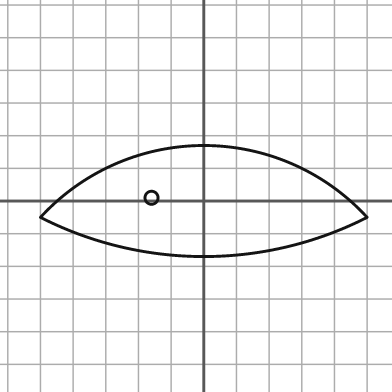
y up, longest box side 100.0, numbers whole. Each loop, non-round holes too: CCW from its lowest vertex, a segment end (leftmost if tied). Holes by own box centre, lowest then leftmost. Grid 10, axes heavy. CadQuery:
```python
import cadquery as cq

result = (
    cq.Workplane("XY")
    .moveTo(-50.0, -5.0)
    .threePointArc((0.0, -17.0), (50.0, -5.0))
    .threePointArc((0.0, 17.0), (-50.0, -5.0))
    .close()
    .moveTo(-16.0, 1.0)
    .circle(2.0)
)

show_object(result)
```